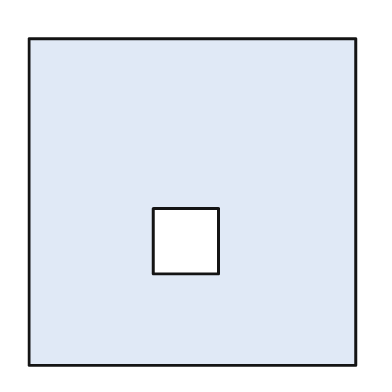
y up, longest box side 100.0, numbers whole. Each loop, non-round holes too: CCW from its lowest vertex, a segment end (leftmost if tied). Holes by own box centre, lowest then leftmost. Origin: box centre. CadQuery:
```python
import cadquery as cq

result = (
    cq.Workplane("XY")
    .moveTo(-50.0, -50.0)
    .lineTo(50.0, -50.0)
    .lineTo(50.0, 50.0)
    .lineTo(-50.0, 50.0)
    .close()
    .moveTo(-12.0, -22.0)
    .lineTo(8.0, -22.0)
    .lineTo(8.0, -2.0)
    .lineTo(-12.0, -2.0)
    .close()
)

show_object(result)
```